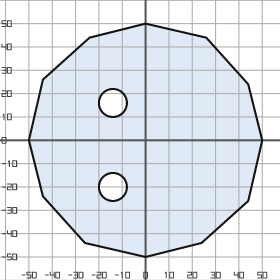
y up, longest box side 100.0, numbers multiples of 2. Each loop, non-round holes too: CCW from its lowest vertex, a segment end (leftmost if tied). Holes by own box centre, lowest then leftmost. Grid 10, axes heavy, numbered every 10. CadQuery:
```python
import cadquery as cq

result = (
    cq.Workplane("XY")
    .moveTo(0.0, -50.0)
    .lineTo(24.0, -44.0)
    .lineTo(44.0, -26.0)
    .lineTo(50.0, 0.0)
    .lineTo(44.0, 24.0)
    .lineTo(26.0, 44.0)
    .lineTo(0.0, 50.0)
    .lineTo(-24.0, 44.0)
    .lineTo(-44.0, 26.0)
    .lineTo(-50.0, 0.0)
    .lineTo(-44.0, -24.0)
    .lineTo(-26.0, -44.0)
    .close()
    .moveTo(-14.0, -20.0)
    .circle(6.0)
    .moveTo(-14.0, 16.0)
    .circle(6.0)
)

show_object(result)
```